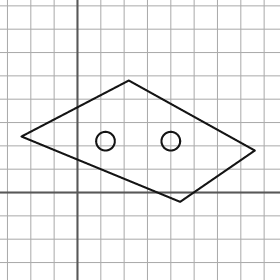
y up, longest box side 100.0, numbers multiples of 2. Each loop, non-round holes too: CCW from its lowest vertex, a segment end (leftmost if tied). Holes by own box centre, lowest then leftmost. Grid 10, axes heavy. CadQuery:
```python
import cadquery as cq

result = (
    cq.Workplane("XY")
    .moveTo(44.0, -4.0)
    .lineTo(76.0, 18.0)
    .lineTo(22.0, 48.0)
    .lineTo(-24.0, 24.0)
    .close()
    .moveTo(12.0, 22.0)
    .circle(4.0)
    .moveTo(40.0, 22.0)
    .circle(4.0)
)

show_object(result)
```